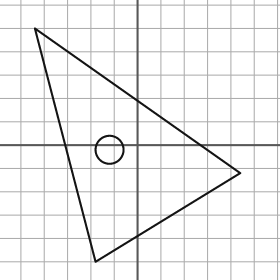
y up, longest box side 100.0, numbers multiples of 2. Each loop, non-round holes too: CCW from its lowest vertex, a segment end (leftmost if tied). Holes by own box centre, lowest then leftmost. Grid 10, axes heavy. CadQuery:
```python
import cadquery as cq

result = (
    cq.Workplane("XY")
    .moveTo(-18.0, -50.0)
    .lineTo(44.0, -12.0)
    .lineTo(-44.0, 50.0)
    .close()
    .moveTo(-12.0, -2.0)
    .circle(6.0)
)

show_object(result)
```